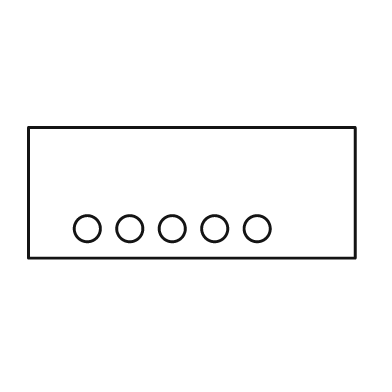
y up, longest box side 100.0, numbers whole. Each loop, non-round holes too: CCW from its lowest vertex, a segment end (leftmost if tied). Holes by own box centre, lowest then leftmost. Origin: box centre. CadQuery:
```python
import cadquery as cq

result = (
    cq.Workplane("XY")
    .moveTo(-50.0, -20.0)
    .lineTo(50.0, -20.0)
    .lineTo(50.0, 20.0)
    .lineTo(-50.0, 20.0)
    .close()
    .moveTo(-32.0, -11.0)
    .circle(4.0)
    .moveTo(-19.0, -11.0)
    .circle(4.0)
    .moveTo(-6.0, -11.0)
    .circle(4.0)
    .moveTo(7.0, -11.0)
    .circle(4.0)
    .moveTo(20.0, -11.0)
    .circle(4.0)
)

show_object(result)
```